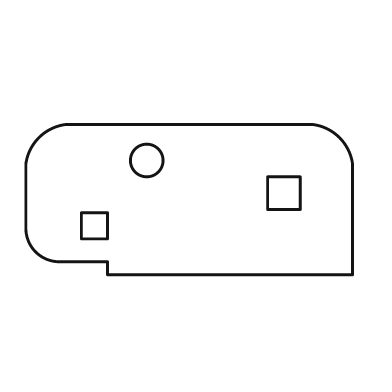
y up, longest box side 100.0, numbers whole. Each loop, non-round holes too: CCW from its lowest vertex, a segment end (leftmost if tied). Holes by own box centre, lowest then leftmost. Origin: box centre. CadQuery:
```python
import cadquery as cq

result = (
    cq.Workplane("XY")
    .moveTo(-25.0, -23.0)
    .lineTo(50.0, -23.0)
    .lineTo(50.0, 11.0)
    .threePointArc((46.0, 19.0), (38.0, 23.0))
    .lineTo(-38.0, 23.0)
    .threePointArc((-46.0, 19.0), (-50.0, 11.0))
    .lineTo(-50.0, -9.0)
    .threePointArc((-47.0, -16.0), (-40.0, -19.0))
    .lineTo(-25.0, -19.0)
    .close()
    .moveTo(-33.0, -12.0)
    .lineTo(-25.0, -12.0)
    .lineTo(-25.0, -4.0)
    .lineTo(-33.0, -4.0)
    .close()
    .moveTo(24.0, -3.0)
    .lineTo(34.0, -3.0)
    .lineTo(34.0, 7.0)
    .lineTo(24.0, 7.0)
    .close()
    .moveTo(-13.0, 12.0)
    .circle(5.0)
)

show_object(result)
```